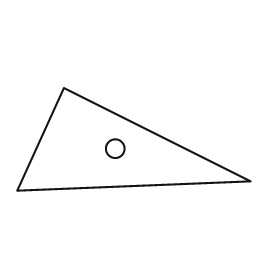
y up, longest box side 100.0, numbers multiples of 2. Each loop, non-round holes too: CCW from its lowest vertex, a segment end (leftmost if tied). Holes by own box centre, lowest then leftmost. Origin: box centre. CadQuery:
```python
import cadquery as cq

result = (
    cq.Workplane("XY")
    .moveTo(-50.0, -22.0)
    .lineTo(50.0, -18.0)
    .lineTo(-30.0, 22.0)
    .close()
    .moveTo(-8.0, -4.0)
    .circle(4.0)
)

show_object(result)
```